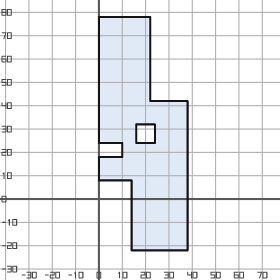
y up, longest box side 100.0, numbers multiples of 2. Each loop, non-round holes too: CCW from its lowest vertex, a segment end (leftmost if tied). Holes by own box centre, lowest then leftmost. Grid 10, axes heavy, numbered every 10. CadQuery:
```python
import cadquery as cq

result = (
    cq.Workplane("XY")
    .moveTo(14.0, -22.0)
    .lineTo(38.0, -22.0)
    .lineTo(38.0, 42.0)
    .lineTo(22.0, 42.0)
    .lineTo(22.0, 78.0)
    .lineTo(0.0, 78.0)
    .lineTo(0.0, 24.0)
    .lineTo(10.0, 24.0)
    .lineTo(10.0, 18.0)
    .lineTo(0.0, 18.0)
    .lineTo(0.0, 8.0)
    .lineTo(14.0, 8.0)
    .close()
    .moveTo(16.0, 24.0)
    .lineTo(24.0, 24.0)
    .lineTo(24.0, 32.0)
    .lineTo(16.0, 32.0)
    .close()
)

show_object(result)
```